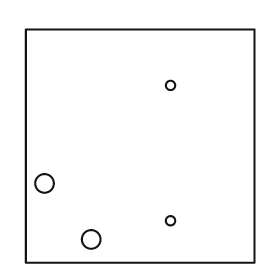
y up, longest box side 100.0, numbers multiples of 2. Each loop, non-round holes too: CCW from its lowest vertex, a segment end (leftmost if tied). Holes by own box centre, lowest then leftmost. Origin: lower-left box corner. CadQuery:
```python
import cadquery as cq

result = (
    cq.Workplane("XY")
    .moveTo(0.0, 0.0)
    .lineTo(98.0, 0.0)
    .lineTo(98.0, 100.0)
    .lineTo(0.0, 100.0)
    .close()
    .moveTo(28.0, 10.0)
    .circle(4.0)
    .moveTo(62.0, 18.0)
    .circle(2.0)
    .moveTo(8.0, 34.0)
    .circle(4.0)
    .moveTo(62.0, 76.0)
    .circle(2.0)
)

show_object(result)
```